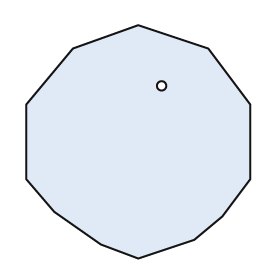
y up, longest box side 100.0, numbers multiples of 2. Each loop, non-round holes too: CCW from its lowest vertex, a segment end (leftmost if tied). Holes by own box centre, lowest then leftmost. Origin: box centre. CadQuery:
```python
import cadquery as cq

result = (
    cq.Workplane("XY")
    .moveTo(0.0, -50.0)
    .lineTo(24.0, -42.0)
    .lineTo(36.0, -32.0)
    .lineTo(48.0, -16.0)
    .lineTo(48.0, 16.0)
    .lineTo(30.0, 40.0)
    .lineTo(0.0, 50.0)
    .lineTo(-28.0, 40.0)
    .lineTo(-48.0, 16.0)
    .lineTo(-48.0, -16.0)
    .lineTo(-36.0, -30.0)
    .lineTo(-16.0, -44.0)
    .close()
    .moveTo(10.0, 24.0)
    .circle(2.0)
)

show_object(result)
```